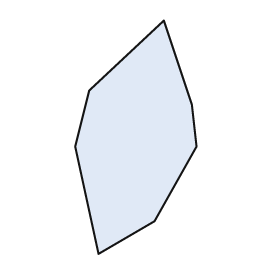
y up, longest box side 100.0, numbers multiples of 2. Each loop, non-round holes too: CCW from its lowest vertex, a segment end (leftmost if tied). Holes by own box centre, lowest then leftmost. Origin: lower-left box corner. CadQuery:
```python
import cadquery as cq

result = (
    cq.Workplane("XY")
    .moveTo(10.0, 0.0)
    .lineTo(34.0, 14.0)
    .lineTo(52.0, 46.0)
    .lineTo(50.0, 64.0)
    .lineTo(38.0, 100.0)
    .lineTo(6.0, 70.0)
    .lineTo(0.0, 46.0)
    .close()
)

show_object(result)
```